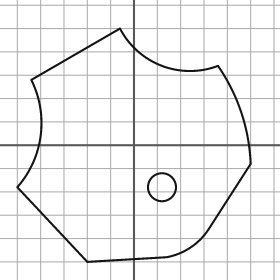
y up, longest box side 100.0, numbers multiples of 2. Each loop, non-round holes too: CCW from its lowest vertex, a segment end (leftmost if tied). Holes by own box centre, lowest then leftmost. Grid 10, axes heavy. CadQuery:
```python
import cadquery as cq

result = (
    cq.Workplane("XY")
    .moveTo(-20.0, -50.0)
    .lineTo(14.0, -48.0)
    .threePointArc((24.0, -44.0), (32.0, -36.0))
    .lineTo(50.0, -8.0)
    .threePointArc((46.0, 14.0), (36.0, 34.0))
    .threePointArc((12.0, 34.0), (-6.0, 50.0))
    .lineTo(-44.0, 28.0)
    .threePointArc((-40.0, 4.0), (-50.0, -18.0))
    .close()
    .moveTo(12.0, -18.0)
    .circle(6.0)
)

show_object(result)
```